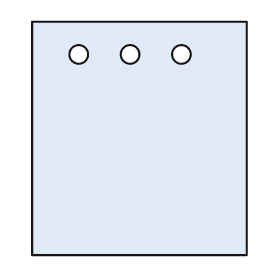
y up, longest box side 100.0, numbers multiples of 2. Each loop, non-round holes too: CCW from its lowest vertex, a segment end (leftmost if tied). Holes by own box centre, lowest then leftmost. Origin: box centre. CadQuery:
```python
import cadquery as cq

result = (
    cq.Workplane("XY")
    .moveTo(-46.0, -50.0)
    .lineTo(46.0, -50.0)
    .lineTo(46.0, 50.0)
    .lineTo(-46.0, 50.0)
    .close()
    .moveTo(-26.0, 36.0)
    .circle(4.0)
    .moveTo(-4.0, 36.0)
    .circle(4.0)
    .moveTo(18.0, 36.0)
    .circle(4.0)
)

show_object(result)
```